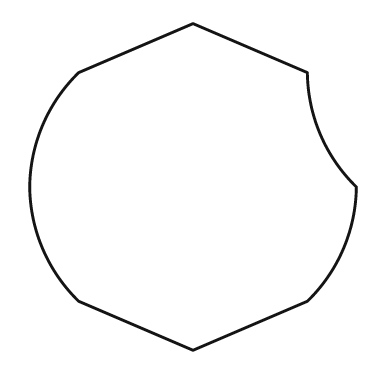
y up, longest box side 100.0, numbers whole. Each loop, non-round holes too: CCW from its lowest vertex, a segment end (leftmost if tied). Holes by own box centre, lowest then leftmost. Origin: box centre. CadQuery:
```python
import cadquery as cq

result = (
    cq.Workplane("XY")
    .moveTo(0.0, -50.0)
    .lineTo(35.0, -35.0)
    .threePointArc((46.0, -19.0), (50.0, 0.0))
    .threePointArc((39.0, 16.0), (35.0, 35.0))
    .lineTo(0.0, 50.0)
    .lineTo(-35.0, 35.0)
    .threePointArc((-46.0, 19.0), (-50.0, 0.0))
    .threePointArc((-46.0, -19.0), (-35.0, -35.0))
    .close()
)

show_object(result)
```